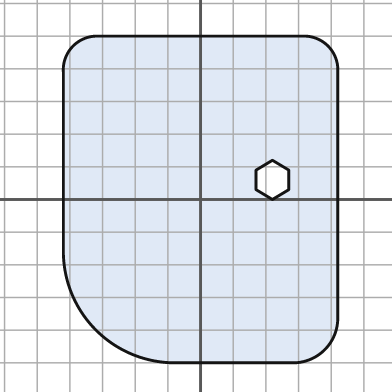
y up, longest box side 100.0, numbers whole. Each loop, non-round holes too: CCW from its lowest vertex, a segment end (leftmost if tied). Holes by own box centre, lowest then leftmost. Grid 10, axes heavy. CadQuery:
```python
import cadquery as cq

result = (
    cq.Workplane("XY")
    .moveTo(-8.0, -50.0)
    .lineTo(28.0, -50.0)
    .threePointArc((38.0, -46.0), (42.0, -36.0))
    .lineTo(42.0, 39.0)
    .threePointArc((39.0, 47.0), (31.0, 50.0))
    .lineTo(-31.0, 50.0)
    .threePointArc((-39.0, 47.0), (-42.0, 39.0))
    .lineTo(-42.0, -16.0)
    .threePointArc((-32.0, -40.0), (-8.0, -50.0))
    .close()
    .moveTo(22.0, 0.0)
    .lineTo(27.0, 3.0)
    .lineTo(27.0, 9.0)
    .lineTo(22.0, 12.0)
    .lineTo(17.0, 9.0)
    .lineTo(17.0, 3.0)
    .close()
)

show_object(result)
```